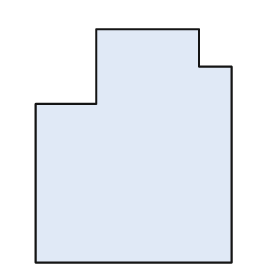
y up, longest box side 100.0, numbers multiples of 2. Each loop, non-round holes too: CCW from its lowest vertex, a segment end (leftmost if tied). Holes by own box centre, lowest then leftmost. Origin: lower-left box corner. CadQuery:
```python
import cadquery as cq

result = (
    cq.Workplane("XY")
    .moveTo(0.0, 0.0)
    .lineTo(84.0, 0.0)
    .lineTo(84.0, 84.0)
    .lineTo(70.0, 84.0)
    .lineTo(70.0, 100.0)
    .lineTo(26.0, 100.0)
    .lineTo(26.0, 68.0)
    .lineTo(0.0, 68.0)
    .close()
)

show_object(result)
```